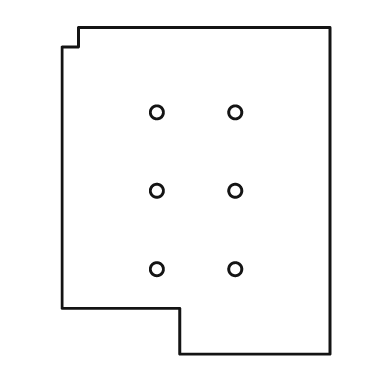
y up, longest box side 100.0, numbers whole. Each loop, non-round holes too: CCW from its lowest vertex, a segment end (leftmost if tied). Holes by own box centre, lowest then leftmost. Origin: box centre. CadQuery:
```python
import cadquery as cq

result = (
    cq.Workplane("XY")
    .moveTo(-5.0, -50.0)
    .lineTo(41.0, -50.0)
    .lineTo(41.0, 50.0)
    .lineTo(-36.0, 50.0)
    .lineTo(-36.0, 44.0)
    .lineTo(-41.0, 44.0)
    .lineTo(-41.0, -36.0)
    .lineTo(-5.0, -36.0)
    .close()
    .moveTo(-12.0, -24.0)
    .circle(2.0)
    .moveTo(12.0, -24.0)
    .circle(2.0)
    .moveTo(-12.0, 0.0)
    .circle(2.0)
    .moveTo(12.0, 0.0)
    .circle(2.0)
    .moveTo(-12.0, 24.0)
    .circle(2.0)
    .moveTo(12.0, 24.0)
    .circle(2.0)
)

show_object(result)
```